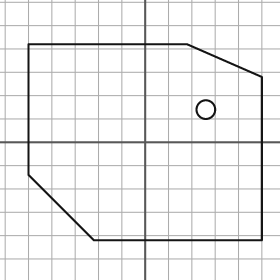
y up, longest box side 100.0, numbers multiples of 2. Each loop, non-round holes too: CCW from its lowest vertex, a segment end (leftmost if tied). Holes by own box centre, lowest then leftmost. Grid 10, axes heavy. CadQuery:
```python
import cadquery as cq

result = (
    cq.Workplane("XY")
    .moveTo(-22.0, -42.0)
    .lineTo(50.0, -42.0)
    .lineTo(50.0, 28.0)
    .lineTo(18.0, 42.0)
    .lineTo(-50.0, 42.0)
    .lineTo(-50.0, -14.0)
    .close()
    .moveTo(26.0, 14.0)
    .circle(4.0)
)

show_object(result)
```